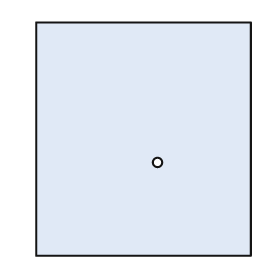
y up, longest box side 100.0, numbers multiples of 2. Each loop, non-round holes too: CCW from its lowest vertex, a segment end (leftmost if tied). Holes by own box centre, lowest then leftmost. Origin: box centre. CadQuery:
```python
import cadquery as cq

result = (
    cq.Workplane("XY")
    .moveTo(-46.0, -50.0)
    .lineTo(46.0, -50.0)
    .lineTo(46.0, 50.0)
    .lineTo(-46.0, 50.0)
    .close()
    .moveTo(6.0, -10.0)
    .circle(2.0)
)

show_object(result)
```